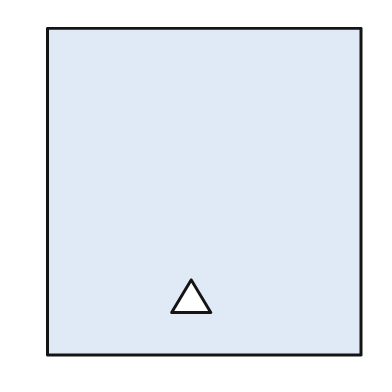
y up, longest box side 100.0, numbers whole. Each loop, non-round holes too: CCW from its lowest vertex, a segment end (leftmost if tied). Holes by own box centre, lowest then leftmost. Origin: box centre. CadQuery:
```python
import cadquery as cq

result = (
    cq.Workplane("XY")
    .moveTo(-48.0, -50.0)
    .lineTo(48.0, -50.0)
    .lineTo(48.0, 50.0)
    .lineTo(-48.0, 50.0)
    .close()
    .moveTo(-10.0, -37.0)
    .lineTo(2.0, -37.0)
    .lineTo(-4.0, -27.0)
    .close()
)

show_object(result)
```